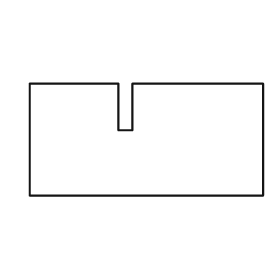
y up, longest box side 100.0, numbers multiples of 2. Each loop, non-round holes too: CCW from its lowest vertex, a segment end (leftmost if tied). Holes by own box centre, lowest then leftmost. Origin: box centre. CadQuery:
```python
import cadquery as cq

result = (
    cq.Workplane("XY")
    .moveTo(-50.0, -24.0)
    .lineTo(50.0, -24.0)
    .lineTo(50.0, 24.0)
    .lineTo(-6.0, 24.0)
    .lineTo(-6.0, 4.0)
    .lineTo(-12.0, 4.0)
    .lineTo(-12.0, 24.0)
    .lineTo(-50.0, 24.0)
    .close()
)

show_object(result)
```